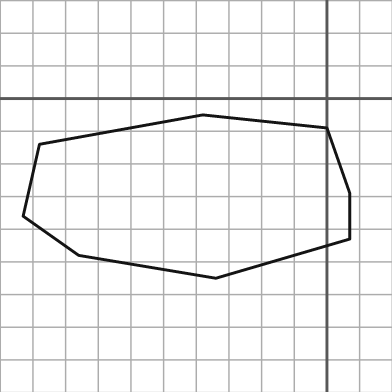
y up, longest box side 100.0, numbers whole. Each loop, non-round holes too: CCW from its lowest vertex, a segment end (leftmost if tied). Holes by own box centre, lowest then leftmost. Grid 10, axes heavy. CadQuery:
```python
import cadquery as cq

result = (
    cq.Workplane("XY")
    .moveTo(-34.0, -55.0)
    .lineTo(7.0, -43.0)
    .lineTo(7.0, -29.0)
    .lineTo(0.0, -9.0)
    .lineTo(-38.0, -5.0)
    .lineTo(-88.0, -14.0)
    .lineTo(-93.0, -36.0)
    .lineTo(-76.0, -48.0)
    .close()
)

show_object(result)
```